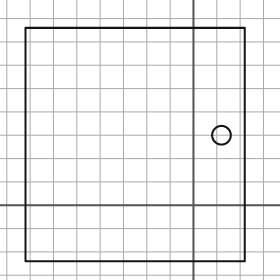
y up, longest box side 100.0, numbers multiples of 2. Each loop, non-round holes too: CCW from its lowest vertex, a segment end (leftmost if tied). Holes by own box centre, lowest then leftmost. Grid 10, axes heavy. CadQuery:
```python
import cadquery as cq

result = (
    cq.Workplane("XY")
    .moveTo(-72.0, -24.0)
    .lineTo(22.0, -24.0)
    .lineTo(22.0, 76.0)
    .lineTo(-72.0, 76.0)
    .close()
    .moveTo(12.0, 30.0)
    .circle(4.0)
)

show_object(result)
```